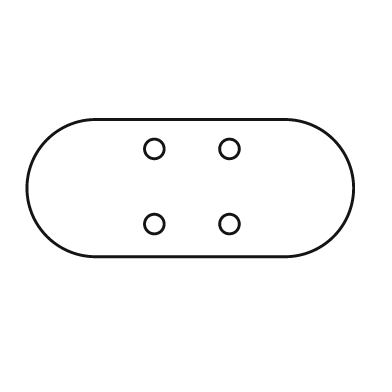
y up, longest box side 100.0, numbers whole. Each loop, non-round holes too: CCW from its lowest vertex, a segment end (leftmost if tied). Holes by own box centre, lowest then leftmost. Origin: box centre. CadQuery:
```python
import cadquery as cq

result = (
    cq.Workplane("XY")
    .moveTo(-29.0, -21.0)
    .lineTo(29.0, -21.0)
    .threePointArc((50.0, 0.0), (29.0, 21.0))
    .lineTo(-29.0, 21.0)
    .threePointArc((-50.0, 0.0), (-29.0, -21.0))
    .close()
    .moveTo(-11.0, -11.0)
    .circle(3.0)
    .moveTo(12.0, -11.0)
    .circle(3.0)
    .moveTo(-11.0, 12.0)
    .circle(3.0)
    .moveTo(12.0, 12.0)
    .circle(3.0)
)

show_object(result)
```